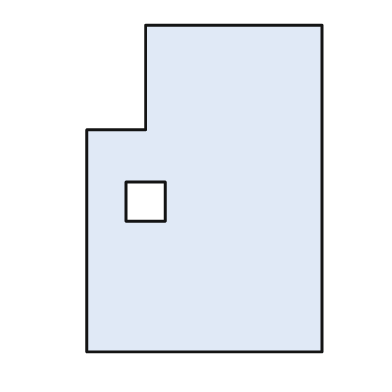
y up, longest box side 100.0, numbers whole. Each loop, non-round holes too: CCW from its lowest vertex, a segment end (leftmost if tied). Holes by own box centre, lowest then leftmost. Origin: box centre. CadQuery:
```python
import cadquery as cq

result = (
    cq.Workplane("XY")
    .moveTo(-36.0, -50.0)
    .lineTo(36.0, -50.0)
    .lineTo(36.0, 50.0)
    .lineTo(-18.0, 50.0)
    .lineTo(-18.0, 18.0)
    .lineTo(-36.0, 18.0)
    .close()
    .moveTo(-24.0, -10.0)
    .lineTo(-12.0, -10.0)
    .lineTo(-12.0, 2.0)
    .lineTo(-24.0, 2.0)
    .close()
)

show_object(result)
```